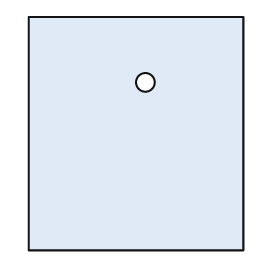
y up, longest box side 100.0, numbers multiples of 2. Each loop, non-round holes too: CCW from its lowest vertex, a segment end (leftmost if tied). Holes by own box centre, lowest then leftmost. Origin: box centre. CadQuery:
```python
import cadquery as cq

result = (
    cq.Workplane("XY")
    .moveTo(-46.0, -50.0)
    .lineTo(46.0, -50.0)
    .lineTo(46.0, 50.0)
    .lineTo(-46.0, 50.0)
    .close()
    .moveTo(4.0, 22.0)
    .circle(4.0)
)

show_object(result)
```